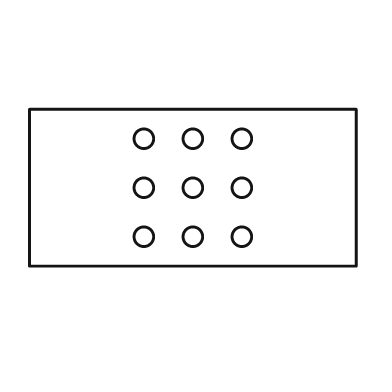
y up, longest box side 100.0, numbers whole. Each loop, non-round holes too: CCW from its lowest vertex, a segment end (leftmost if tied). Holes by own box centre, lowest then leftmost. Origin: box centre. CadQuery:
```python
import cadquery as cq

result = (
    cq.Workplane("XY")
    .moveTo(-50.0, -24.0)
    .lineTo(50.0, -24.0)
    .lineTo(50.0, 24.0)
    .lineTo(-50.0, 24.0)
    .close()
    .moveTo(-15.0, -15.0)
    .circle(3.0)
    .moveTo(0.0, -15.0)
    .circle(3.0)
    .moveTo(15.0, -15.0)
    .circle(3.0)
    .moveTo(-15.0, 0.0)
    .circle(3.0)
    .moveTo(0.0, 0.0)
    .circle(3.0)
    .moveTo(15.0, 0.0)
    .circle(3.0)
    .moveTo(-15.0, 15.0)
    .circle(3.0)
    .moveTo(0.0, 15.0)
    .circle(3.0)
    .moveTo(15.0, 15.0)
    .circle(3.0)
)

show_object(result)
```